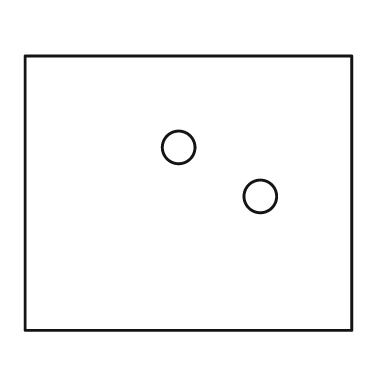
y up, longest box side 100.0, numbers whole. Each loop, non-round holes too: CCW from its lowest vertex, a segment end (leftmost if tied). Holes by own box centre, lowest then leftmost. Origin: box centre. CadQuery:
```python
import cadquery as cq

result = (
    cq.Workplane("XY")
    .moveTo(-50.0, -42.0)
    .lineTo(50.0, -42.0)
    .lineTo(50.0, 42.0)
    .lineTo(-50.0, 42.0)
    .close()
    .moveTo(22.0, -1.0)
    .circle(5.0)
    .moveTo(-3.0, 14.0)
    .circle(5.0)
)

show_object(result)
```